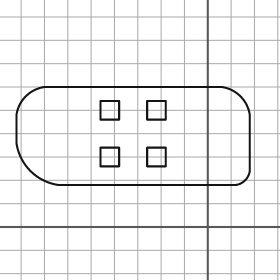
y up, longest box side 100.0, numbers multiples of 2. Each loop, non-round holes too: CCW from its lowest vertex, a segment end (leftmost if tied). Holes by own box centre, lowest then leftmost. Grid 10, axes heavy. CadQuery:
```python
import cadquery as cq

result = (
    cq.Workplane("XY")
    .moveTo(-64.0, 18.0)
    .lineTo(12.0, 18.0)
    .threePointArc((16.0, 20.0), (18.0, 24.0))
    .lineTo(18.0, 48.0)
    .threePointArc((14.0, 56.0), (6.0, 60.0))
    .lineTo(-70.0, 60.0)
    .threePointArc((-78.0, 56.0), (-82.0, 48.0))
    .lineTo(-82.0, 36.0)
    .threePointArc((-76.0, 24.0), (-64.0, 18.0))
    .close()
    .moveTo(-46.0, 26.0)
    .lineTo(-38.0, 26.0)
    .lineTo(-38.0, 34.0)
    .lineTo(-46.0, 34.0)
    .close()
    .moveTo(-26.0, 26.0)
    .lineTo(-18.0, 26.0)
    .lineTo(-18.0, 34.0)
    .lineTo(-26.0, 34.0)
    .close()
    .moveTo(-46.0, 46.0)
    .lineTo(-38.0, 46.0)
    .lineTo(-38.0, 54.0)
    .lineTo(-46.0, 54.0)
    .close()
    .moveTo(-26.0, 46.0)
    .lineTo(-18.0, 46.0)
    .lineTo(-18.0, 54.0)
    .lineTo(-26.0, 54.0)
    .close()
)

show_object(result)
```